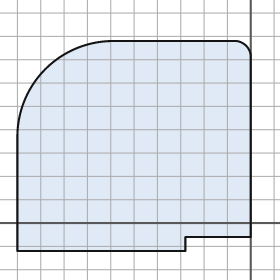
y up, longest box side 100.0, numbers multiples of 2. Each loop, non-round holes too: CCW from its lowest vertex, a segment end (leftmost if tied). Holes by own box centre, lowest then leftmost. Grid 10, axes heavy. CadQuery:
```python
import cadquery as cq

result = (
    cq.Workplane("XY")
    .moveTo(-100.0, -12.0)
    .lineTo(-28.0, -12.0)
    .lineTo(-28.0, -6.0)
    .lineTo(0.0, -6.0)
    .lineTo(0.0, 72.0)
    .threePointArc((-2.0, 76.0), (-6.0, 78.0))
    .lineTo(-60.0, 78.0)
    .threePointArc((-88.0, 66.0), (-100.0, 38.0))
    .close()
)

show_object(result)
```